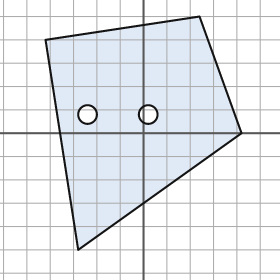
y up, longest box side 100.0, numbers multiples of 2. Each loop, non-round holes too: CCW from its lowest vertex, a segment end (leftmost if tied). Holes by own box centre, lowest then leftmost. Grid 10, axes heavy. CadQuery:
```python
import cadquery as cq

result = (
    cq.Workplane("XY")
    .moveTo(-28.0, -50.0)
    .lineTo(42.0, 0.0)
    .lineTo(24.0, 50.0)
    .lineTo(-42.0, 40.0)
    .close()
    .moveTo(-24.0, 8.0)
    .circle(4.0)
    .moveTo(2.0, 8.0)
    .circle(4.0)
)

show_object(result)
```